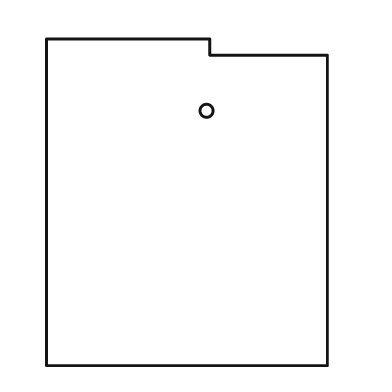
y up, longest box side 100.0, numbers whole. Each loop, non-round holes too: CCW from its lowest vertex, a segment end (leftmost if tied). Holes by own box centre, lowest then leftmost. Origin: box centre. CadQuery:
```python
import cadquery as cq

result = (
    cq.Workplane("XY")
    .moveTo(-43.0, -50.0)
    .lineTo(43.0, -50.0)
    .lineTo(43.0, 45.0)
    .lineTo(7.0, 45.0)
    .lineTo(7.0, 50.0)
    .lineTo(-43.0, 50.0)
    .close()
    .moveTo(6.0, 28.0)
    .circle(2.0)
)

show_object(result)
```